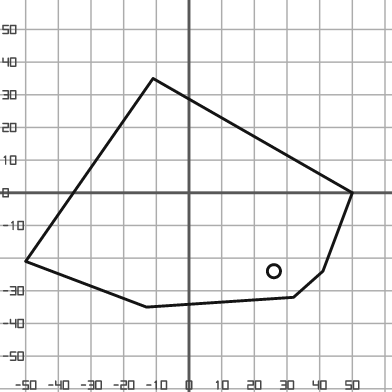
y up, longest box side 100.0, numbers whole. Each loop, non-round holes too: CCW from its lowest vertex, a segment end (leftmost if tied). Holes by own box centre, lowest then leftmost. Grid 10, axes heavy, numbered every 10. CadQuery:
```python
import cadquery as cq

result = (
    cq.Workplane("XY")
    .moveTo(-13.0, -35.0)
    .lineTo(32.0, -32.0)
    .lineTo(41.0, -24.0)
    .lineTo(50.0, 0.0)
    .lineTo(-11.0, 35.0)
    .lineTo(-50.0, -21.0)
    .close()
    .moveTo(26.0, -24.0)
    .circle(2.0)
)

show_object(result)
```